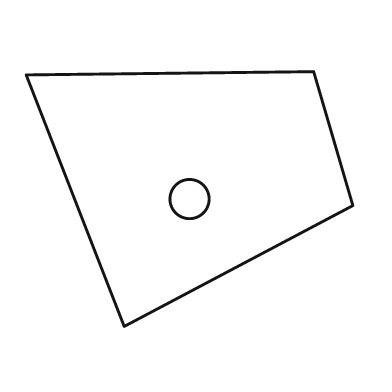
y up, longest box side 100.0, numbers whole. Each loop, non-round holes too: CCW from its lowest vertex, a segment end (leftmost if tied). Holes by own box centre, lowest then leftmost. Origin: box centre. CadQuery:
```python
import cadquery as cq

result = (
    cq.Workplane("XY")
    .moveTo(-20.0, -39.0)
    .lineTo(50.0, -2.0)
    .lineTo(38.0, 39.0)
    .lineTo(-50.0, 38.0)
    .close()
    .moveTo(0.0, 0.0)
    .circle(6.0)
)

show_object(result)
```